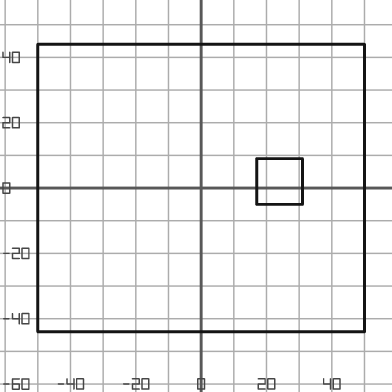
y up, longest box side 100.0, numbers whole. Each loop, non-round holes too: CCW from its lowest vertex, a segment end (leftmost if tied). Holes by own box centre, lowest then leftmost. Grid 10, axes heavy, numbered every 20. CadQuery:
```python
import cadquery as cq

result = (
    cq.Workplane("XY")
    .moveTo(-50.0, -44.0)
    .lineTo(50.0, -44.0)
    .lineTo(50.0, 44.0)
    .lineTo(-50.0, 44.0)
    .close()
    .moveTo(17.0, -5.0)
    .lineTo(31.0, -5.0)
    .lineTo(31.0, 9.0)
    .lineTo(17.0, 9.0)
    .close()
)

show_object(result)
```